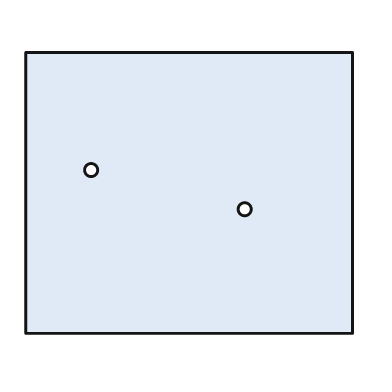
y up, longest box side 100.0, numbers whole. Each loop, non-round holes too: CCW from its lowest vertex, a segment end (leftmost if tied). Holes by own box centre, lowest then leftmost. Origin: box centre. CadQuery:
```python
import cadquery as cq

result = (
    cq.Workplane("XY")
    .moveTo(-50.0, -43.0)
    .lineTo(50.0, -43.0)
    .lineTo(50.0, 43.0)
    .lineTo(-50.0, 43.0)
    .close()
    .moveTo(17.0, -5.0)
    .circle(2.0)
    .moveTo(-30.0, 7.0)
    .circle(2.0)
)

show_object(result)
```